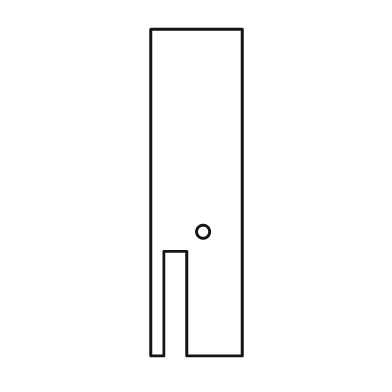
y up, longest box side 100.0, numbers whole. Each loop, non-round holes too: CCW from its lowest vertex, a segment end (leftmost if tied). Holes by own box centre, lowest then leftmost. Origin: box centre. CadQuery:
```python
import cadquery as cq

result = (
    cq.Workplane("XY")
    .moveTo(-14.0, -50.0)
    .lineTo(-10.0, -50.0)
    .lineTo(-10.0, -18.0)
    .lineTo(-3.0, -18.0)
    .lineTo(-3.0, -50.0)
    .lineTo(14.0, -50.0)
    .lineTo(14.0, 50.0)
    .lineTo(-14.0, 50.0)
    .close()
    .moveTo(2.0, -12.0)
    .circle(2.0)
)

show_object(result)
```